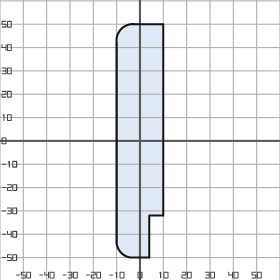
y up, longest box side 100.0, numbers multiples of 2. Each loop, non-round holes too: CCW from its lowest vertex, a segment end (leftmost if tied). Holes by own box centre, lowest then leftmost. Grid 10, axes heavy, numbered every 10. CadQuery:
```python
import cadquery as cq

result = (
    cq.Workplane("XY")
    .moveTo(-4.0, -50.0)
    .lineTo(4.0, -50.0)
    .lineTo(4.0, -32.0)
    .lineTo(10.0, -32.0)
    .lineTo(10.0, 50.0)
    .lineTo(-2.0, 50.0)
    .threePointArc((-8.0, 48.0), (-10.0, 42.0))
    .lineTo(-10.0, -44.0)
    .threePointArc((-8.0, -48.0), (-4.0, -50.0))
    .close()
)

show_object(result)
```